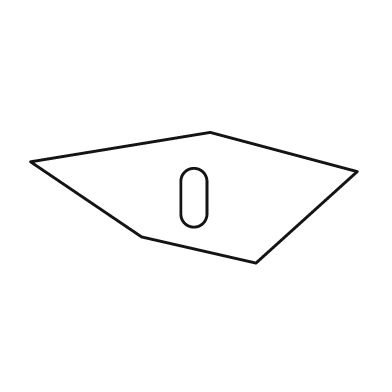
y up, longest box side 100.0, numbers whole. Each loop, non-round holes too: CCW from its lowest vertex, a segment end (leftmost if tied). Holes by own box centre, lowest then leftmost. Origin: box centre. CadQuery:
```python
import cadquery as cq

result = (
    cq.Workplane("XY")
    .moveTo(19.0, -20.0)
    .lineTo(50.0, 8.0)
    .lineTo(5.0, 20.0)
    .lineTo(-50.0, 11.0)
    .lineTo(-16.0, -12.0)
    .close()
    .moveTo(-4.0, -5.0)
    .threePointArc((0.0, -9.0), (4.0, -5.0))
    .lineTo(4.0, 5.0)
    .threePointArc((0.0, 9.0), (-4.0, 5.0))
    .close()
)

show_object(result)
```